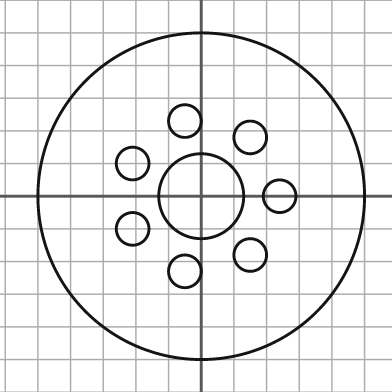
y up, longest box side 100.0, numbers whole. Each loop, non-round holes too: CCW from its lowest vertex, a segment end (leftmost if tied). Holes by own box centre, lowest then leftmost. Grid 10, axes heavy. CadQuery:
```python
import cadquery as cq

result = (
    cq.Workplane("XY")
    .moveTo(0.0, 0.0)
    .circle(50.0)
    .moveTo(-5.0, -23.0)
    .circle(5.0)
    .moveTo(15.0, -18.0)
    .circle(5.0)
    .moveTo(-21.0, -10.0)
    .circle(5.0)
    .moveTo(0.0, 0.0)
    .circle(13.0)
    .moveTo(24.0, 0.0)
    .circle(5.0)
    .moveTo(-21.0, 10.0)
    .circle(5.0)
    .moveTo(15.0, 18.0)
    .circle(5.0)
    .moveTo(-5.0, 23.0)
    .circle(5.0)
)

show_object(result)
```